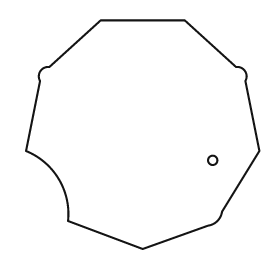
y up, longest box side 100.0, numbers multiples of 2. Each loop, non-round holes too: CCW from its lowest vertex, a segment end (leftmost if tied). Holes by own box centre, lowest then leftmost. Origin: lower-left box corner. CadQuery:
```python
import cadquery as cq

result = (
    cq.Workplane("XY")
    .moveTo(50.0, 0.0)
    .lineTo(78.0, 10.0)
    .threePointArc((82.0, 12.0), (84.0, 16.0))
    .lineTo(100.0, 42.0)
    .lineTo(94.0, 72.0)
    .threePointArc((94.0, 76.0), (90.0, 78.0))
    .lineTo(68.0, 98.0)
    .lineTo(32.0, 98.0)
    .lineTo(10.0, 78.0)
    .threePointArc((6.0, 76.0), (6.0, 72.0))
    .lineTo(0.0, 42.0)
    .threePointArc((14.0, 30.0), (18.0, 12.0))
    .close()
    .moveTo(80.0, 38.0)
    .circle(2.0)
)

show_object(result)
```